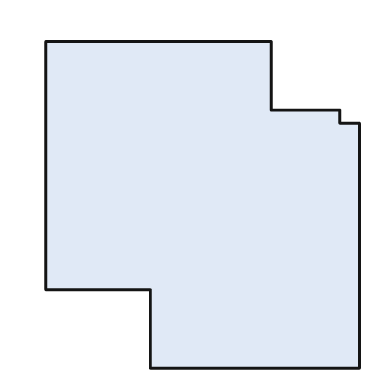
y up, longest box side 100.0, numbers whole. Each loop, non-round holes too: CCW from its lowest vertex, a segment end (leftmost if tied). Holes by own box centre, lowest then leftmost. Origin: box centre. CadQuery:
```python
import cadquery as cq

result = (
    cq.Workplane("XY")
    .moveTo(-16.0, -50.0)
    .lineTo(48.0, -50.0)
    .lineTo(48.0, 25.0)
    .lineTo(42.0, 25.0)
    .lineTo(42.0, 29.0)
    .lineTo(21.0, 29.0)
    .lineTo(21.0, 50.0)
    .lineTo(-48.0, 50.0)
    .lineTo(-48.0, -26.0)
    .lineTo(-16.0, -26.0)
    .close()
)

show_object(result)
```